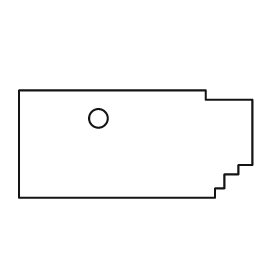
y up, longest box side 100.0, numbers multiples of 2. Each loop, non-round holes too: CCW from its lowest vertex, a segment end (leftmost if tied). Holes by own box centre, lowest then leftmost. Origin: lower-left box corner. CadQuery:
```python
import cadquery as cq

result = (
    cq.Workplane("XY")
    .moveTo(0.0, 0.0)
    .lineTo(84.0, 0.0)
    .lineTo(84.0, 4.0)
    .lineTo(88.0, 4.0)
    .lineTo(88.0, 10.0)
    .lineTo(94.0, 10.0)
    .lineTo(94.0, 14.0)
    .lineTo(100.0, 14.0)
    .lineTo(100.0, 42.0)
    .lineTo(80.0, 42.0)
    .lineTo(80.0, 46.0)
    .lineTo(0.0, 46.0)
    .close()
    .moveTo(34.0, 34.0)
    .circle(4.0)
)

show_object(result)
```